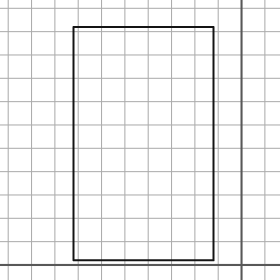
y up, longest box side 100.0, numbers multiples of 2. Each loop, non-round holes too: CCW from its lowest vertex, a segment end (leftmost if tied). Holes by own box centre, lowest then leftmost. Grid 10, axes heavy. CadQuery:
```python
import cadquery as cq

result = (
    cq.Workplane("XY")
    .moveTo(-72.0, 2.0)
    .lineTo(-12.0, 2.0)
    .lineTo(-12.0, 102.0)
    .lineTo(-72.0, 102.0)
    .close()
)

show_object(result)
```